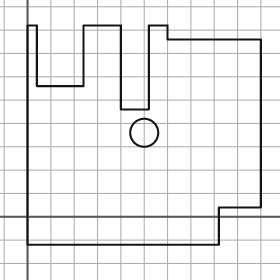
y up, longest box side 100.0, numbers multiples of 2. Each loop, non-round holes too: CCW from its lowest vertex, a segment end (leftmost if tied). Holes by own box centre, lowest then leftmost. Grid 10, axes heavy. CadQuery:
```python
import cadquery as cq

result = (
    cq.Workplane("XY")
    .moveTo(0.0, -12.0)
    .lineTo(82.0, -12.0)
    .lineTo(82.0, 4.0)
    .lineTo(100.0, 4.0)
    .lineTo(100.0, 76.0)
    .lineTo(60.0, 76.0)
    .lineTo(60.0, 82.0)
    .lineTo(52.0, 82.0)
    .lineTo(52.0, 46.0)
    .lineTo(40.0, 46.0)
    .lineTo(40.0, 82.0)
    .lineTo(24.0, 82.0)
    .lineTo(24.0, 56.0)
    .lineTo(4.0, 56.0)
    .lineTo(4.0, 82.0)
    .lineTo(0.0, 82.0)
    .close()
    .moveTo(50.0, 36.0)
    .circle(6.0)
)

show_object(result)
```